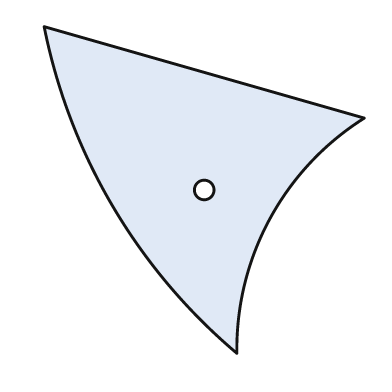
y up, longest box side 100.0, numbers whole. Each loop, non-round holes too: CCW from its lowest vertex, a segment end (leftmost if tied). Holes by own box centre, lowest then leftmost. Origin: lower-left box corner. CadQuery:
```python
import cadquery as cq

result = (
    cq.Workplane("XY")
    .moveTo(59.0, 0.0)
    .threePointArc((69.0, 41.0), (98.0, 72.0))
    .lineTo(0.0, 100.0)
    .threePointArc((21.0, 45.0), (59.0, 0.0))
    .close()
    .moveTo(49.0, 50.0)
    .circle(3.0)
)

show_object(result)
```